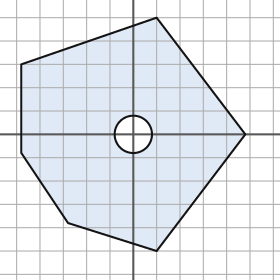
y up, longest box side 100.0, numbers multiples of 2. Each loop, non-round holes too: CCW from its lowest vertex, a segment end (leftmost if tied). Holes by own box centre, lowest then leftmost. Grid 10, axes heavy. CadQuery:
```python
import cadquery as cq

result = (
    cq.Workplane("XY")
    .moveTo(10.0, -50.0)
    .lineTo(48.0, 0.0)
    .lineTo(10.0, 50.0)
    .lineTo(-48.0, 30.0)
    .lineTo(-48.0, -8.0)
    .lineTo(-28.0, -38.0)
    .close()
    .moveTo(0.0, 0.0)
    .circle(8.0)
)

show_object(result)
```